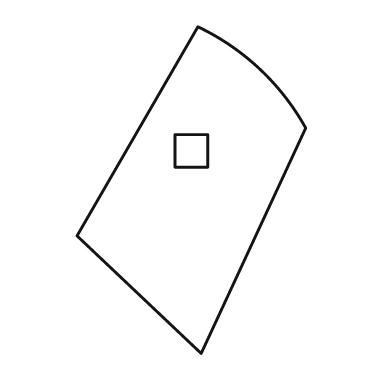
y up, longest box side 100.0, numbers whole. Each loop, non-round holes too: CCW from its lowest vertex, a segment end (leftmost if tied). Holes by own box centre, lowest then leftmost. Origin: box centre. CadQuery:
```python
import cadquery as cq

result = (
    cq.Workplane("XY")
    .moveTo(3.0, -50.0)
    .lineTo(35.0, 19.0)
    .threePointArc((21.0, 37.0), (2.0, 50.0))
    .lineTo(-35.0, -14.0)
    .close()
    .moveTo(-5.0, 7.0)
    .lineTo(5.0, 7.0)
    .lineTo(5.0, 17.0)
    .lineTo(-5.0, 17.0)
    .close()
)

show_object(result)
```